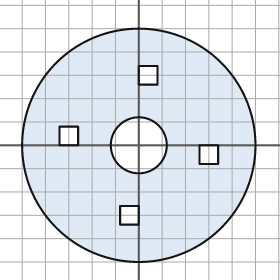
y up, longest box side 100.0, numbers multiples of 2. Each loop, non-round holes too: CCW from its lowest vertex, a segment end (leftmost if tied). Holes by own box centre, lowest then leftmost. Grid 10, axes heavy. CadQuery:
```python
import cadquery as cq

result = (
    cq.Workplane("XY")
    .moveTo(0.0, 0.0)
    .circle(50.0)
    .moveTo(-8.0, -34.0)
    .lineTo(0.0, -34.0)
    .lineTo(0.0, -26.0)
    .lineTo(-8.0, -26.0)
    .close()
    .moveTo(26.0, -8.0)
    .lineTo(34.0, -8.0)
    .lineTo(34.0, 0.0)
    .lineTo(26.0, 0.0)
    .close()
    .moveTo(0.0, 0.0)
    .circle(12.0)
    .moveTo(-34.0, 0.0)
    .lineTo(-26.0, 0.0)
    .lineTo(-26.0, 8.0)
    .lineTo(-34.0, 8.0)
    .close()
    .moveTo(0.0, 26.0)
    .lineTo(8.0, 26.0)
    .lineTo(8.0, 34.0)
    .lineTo(0.0, 34.0)
    .close()
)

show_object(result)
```